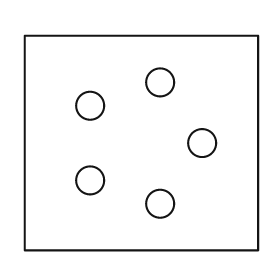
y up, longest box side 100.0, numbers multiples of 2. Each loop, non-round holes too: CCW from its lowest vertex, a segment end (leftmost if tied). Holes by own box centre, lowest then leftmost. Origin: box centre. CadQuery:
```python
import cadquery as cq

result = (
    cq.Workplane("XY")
    .moveTo(-50.0, -46.0)
    .lineTo(50.0, -46.0)
    .lineTo(50.0, 46.0)
    .lineTo(-50.0, 46.0)
    .close()
    .moveTo(8.0, -26.0)
    .circle(6.0)
    .moveTo(-22.0, -16.0)
    .circle(6.0)
    .moveTo(26.0, 0.0)
    .circle(6.0)
    .moveTo(-22.0, 16.0)
    .circle(6.0)
    .moveTo(8.0, 26.0)
    .circle(6.0)
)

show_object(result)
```